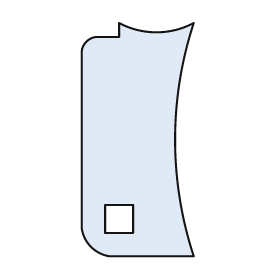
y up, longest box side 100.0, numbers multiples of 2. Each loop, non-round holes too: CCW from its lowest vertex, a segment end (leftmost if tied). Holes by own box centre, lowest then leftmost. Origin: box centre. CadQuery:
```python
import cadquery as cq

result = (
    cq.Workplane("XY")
    .moveTo(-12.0, -50.0)
    .lineTo(24.0, -50.0)
    .threePointArc((16.0, 0.0), (24.0, 50.0))
    .threePointArc((8.0, 46.0), (-8.0, 50.0))
    .lineTo(-8.0, 44.0)
    .lineTo(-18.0, 44.0)
    .threePointArc((-22.0, 42.0), (-24.0, 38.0))
    .lineTo(-24.0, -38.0)
    .threePointArc((-20.0, -46.0), (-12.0, -50.0))
    .close()
    .moveTo(-14.0, -40.0)
    .lineTo(-2.0, -40.0)
    .lineTo(-2.0, -28.0)
    .lineTo(-14.0, -28.0)
    .close()
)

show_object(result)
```